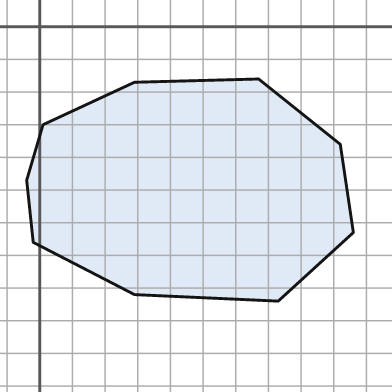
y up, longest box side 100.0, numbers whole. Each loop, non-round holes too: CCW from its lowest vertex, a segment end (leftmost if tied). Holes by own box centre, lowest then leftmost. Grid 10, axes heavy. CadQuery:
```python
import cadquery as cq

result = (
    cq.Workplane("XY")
    .moveTo(73.0, -84.0)
    .lineTo(96.0, -63.0)
    .lineTo(92.0, -36.0)
    .lineTo(67.0, -16.0)
    .lineTo(29.0, -17.0)
    .lineTo(1.0, -30.0)
    .lineTo(-4.0, -47.0)
    .lineTo(-2.0, -66.0)
    .lineTo(29.0, -82.0)
    .close()
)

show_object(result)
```